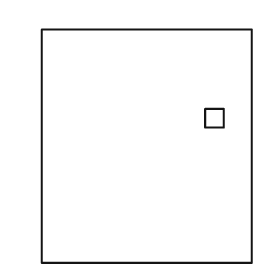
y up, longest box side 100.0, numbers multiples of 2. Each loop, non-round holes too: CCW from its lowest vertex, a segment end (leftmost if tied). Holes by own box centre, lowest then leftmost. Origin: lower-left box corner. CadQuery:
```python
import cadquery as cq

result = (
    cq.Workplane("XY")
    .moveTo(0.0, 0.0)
    .lineTo(90.0, 0.0)
    .lineTo(90.0, 100.0)
    .lineTo(0.0, 100.0)
    .close()
    .moveTo(70.0, 58.0)
    .lineTo(78.0, 58.0)
    .lineTo(78.0, 66.0)
    .lineTo(70.0, 66.0)
    .close()
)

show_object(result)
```